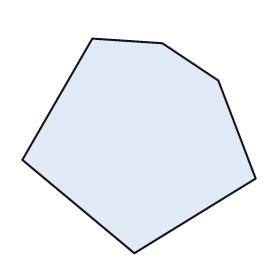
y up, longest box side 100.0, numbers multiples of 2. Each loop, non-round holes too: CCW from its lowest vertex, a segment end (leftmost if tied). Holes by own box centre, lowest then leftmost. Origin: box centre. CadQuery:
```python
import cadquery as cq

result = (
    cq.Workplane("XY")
    .moveTo(-2.0, -46.0)
    .lineTo(50.0, -14.0)
    .lineTo(34.0, 28.0)
    .lineTo(10.0, 44.0)
    .lineTo(-20.0, 46.0)
    .lineTo(-50.0, -6.0)
    .close()
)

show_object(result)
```